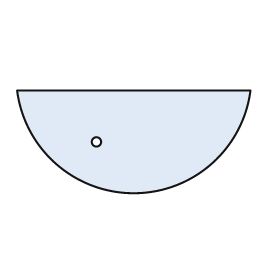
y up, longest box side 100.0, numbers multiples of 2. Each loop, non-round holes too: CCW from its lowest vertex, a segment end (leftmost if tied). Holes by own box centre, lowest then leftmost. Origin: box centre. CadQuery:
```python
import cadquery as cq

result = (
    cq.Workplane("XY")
    .moveTo(-50.0, 22.0)
    .threePointArc((0.0, -22.0), (50.0, 22.0))
    .close()
    .moveTo(-16.0, 0.0)
    .circle(2.0)
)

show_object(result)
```